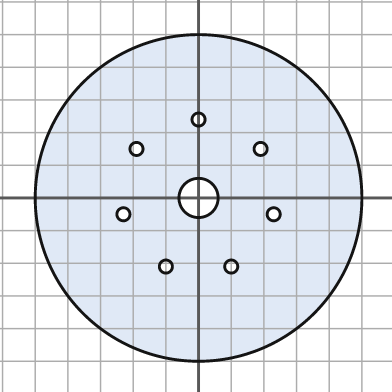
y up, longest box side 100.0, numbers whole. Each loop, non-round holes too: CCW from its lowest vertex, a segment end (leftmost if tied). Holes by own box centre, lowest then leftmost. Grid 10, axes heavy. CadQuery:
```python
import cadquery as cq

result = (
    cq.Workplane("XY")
    .moveTo(0.0, 0.0)
    .circle(50.0)
    .moveTo(-10.0, -21.0)
    .circle(2.0)
    .moveTo(10.0, -21.0)
    .circle(2.0)
    .moveTo(-23.0, -5.0)
    .circle(2.0)
    .moveTo(23.0, -5.0)
    .circle(2.0)
    .moveTo(0.0, 0.0)
    .circle(6.0)
    .moveTo(-19.0, 15.0)
    .circle(2.0)
    .moveTo(19.0, 15.0)
    .circle(2.0)
    .moveTo(0.0, 24.0)
    .circle(2.0)
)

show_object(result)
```